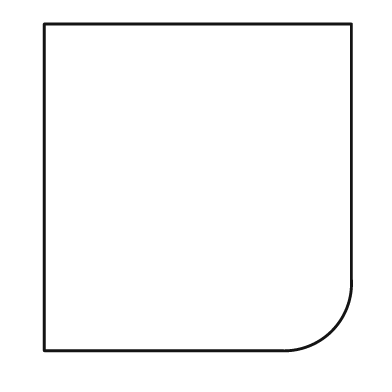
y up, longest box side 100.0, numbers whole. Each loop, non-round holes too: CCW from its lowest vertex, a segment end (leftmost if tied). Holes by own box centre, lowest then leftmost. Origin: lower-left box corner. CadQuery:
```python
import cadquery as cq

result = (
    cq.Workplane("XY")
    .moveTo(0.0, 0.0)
    .lineTo(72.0, 0.0)
    .threePointArc((88.0, 6.0), (94.0, 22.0))
    .lineTo(94.0, 100.0)
    .lineTo(0.0, 100.0)
    .close()
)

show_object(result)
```